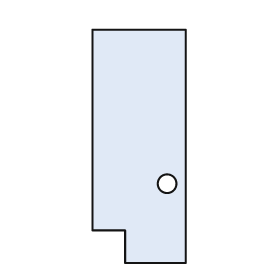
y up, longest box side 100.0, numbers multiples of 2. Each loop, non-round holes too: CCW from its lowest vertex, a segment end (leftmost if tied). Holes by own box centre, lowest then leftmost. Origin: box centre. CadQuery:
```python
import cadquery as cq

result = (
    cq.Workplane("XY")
    .moveTo(-6.0, -50.0)
    .lineTo(20.0, -50.0)
    .lineTo(20.0, 50.0)
    .lineTo(-20.0, 50.0)
    .lineTo(-20.0, -36.0)
    .lineTo(-6.0, -36.0)
    .close()
    .moveTo(12.0, -16.0)
    .circle(4.0)
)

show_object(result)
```